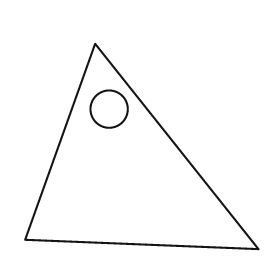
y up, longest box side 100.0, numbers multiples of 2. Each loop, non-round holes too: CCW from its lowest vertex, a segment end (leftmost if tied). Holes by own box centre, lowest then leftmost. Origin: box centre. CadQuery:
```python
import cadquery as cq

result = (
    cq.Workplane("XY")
    .moveTo(50.0, -44.0)
    .lineTo(-20.0, 44.0)
    .lineTo(-50.0, -40.0)
    .close()
    .moveTo(-14.0, 16.0)
    .circle(8.0)
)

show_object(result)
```